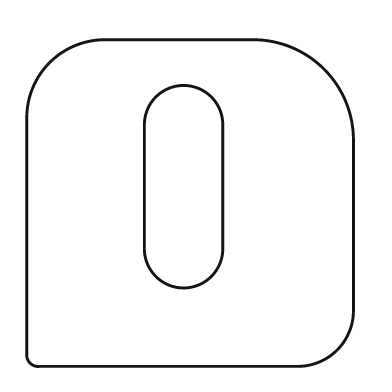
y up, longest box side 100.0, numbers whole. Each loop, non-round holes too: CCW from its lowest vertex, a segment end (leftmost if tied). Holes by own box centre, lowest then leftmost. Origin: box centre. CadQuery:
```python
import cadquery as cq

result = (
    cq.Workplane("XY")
    .moveTo(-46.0, -50.0)
    .lineTo(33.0, -50.0)
    .threePointArc((45.0, -45.0), (50.0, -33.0))
    .lineTo(50.0, 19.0)
    .threePointArc((41.0, 41.0), (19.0, 50.0))
    .lineTo(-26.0, 50.0)
    .threePointArc((-43.0, 43.0), (-50.0, 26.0))
    .lineTo(-50.0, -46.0)
    .threePointArc((-49.0, -49.0), (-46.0, -50.0))
    .close()
    .moveTo(-14.0, -14.0)
    .threePointArc((-2.0, -26.0), (10.0, -14.0))
    .lineTo(10.0, 24.0)
    .threePointArc((-2.0, 36.0), (-14.0, 24.0))
    .close()
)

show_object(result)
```